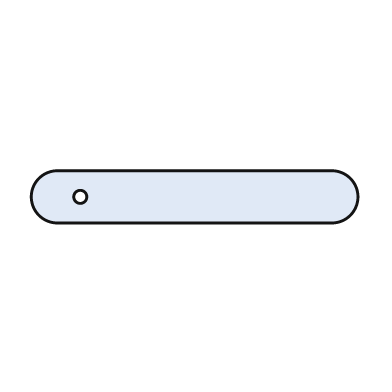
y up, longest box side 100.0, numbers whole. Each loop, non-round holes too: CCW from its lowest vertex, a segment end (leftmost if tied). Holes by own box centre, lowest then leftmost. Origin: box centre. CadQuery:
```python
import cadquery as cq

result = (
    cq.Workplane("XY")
    .moveTo(-42.0, -8.0)
    .lineTo(42.0, -8.0)
    .threePointArc((50.0, 0.0), (42.0, 8.0))
    .lineTo(-42.0, 8.0)
    .threePointArc((-50.0, 0.0), (-42.0, -8.0))
    .close()
    .moveTo(-35.0, 0.0)
    .circle(2.0)
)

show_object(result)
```